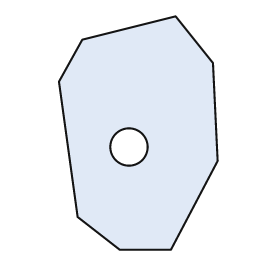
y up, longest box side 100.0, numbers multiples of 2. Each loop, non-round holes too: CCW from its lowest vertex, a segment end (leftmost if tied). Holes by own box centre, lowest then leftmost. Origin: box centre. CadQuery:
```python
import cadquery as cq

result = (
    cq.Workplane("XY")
    .moveTo(-8.0, -50.0)
    .lineTo(14.0, -50.0)
    .lineTo(34.0, -12.0)
    .lineTo(32.0, 30.0)
    .lineTo(16.0, 50.0)
    .lineTo(-24.0, 40.0)
    .lineTo(-34.0, 22.0)
    .lineTo(-26.0, -36.0)
    .close()
    .moveTo(-4.0, -6.0)
    .circle(8.0)
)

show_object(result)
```